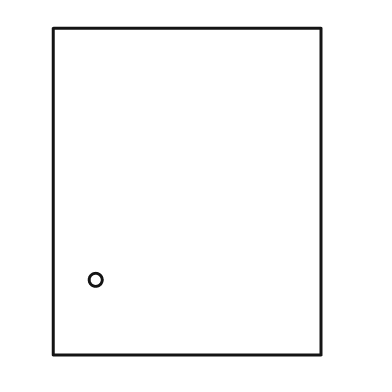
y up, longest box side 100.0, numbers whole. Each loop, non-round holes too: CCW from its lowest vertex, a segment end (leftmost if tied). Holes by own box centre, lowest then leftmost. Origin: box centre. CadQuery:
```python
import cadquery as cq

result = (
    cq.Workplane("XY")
    .moveTo(-41.0, -50.0)
    .lineTo(41.0, -50.0)
    .lineTo(41.0, 50.0)
    .lineTo(-41.0, 50.0)
    .close()
    .moveTo(-28.0, -27.0)
    .circle(2.0)
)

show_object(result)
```